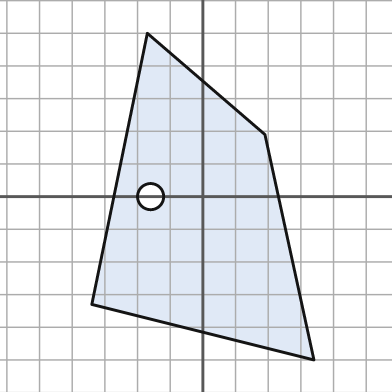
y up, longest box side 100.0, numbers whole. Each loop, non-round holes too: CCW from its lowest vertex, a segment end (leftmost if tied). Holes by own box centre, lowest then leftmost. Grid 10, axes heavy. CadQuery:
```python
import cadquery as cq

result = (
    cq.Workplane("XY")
    .moveTo(34.0, -50.0)
    .lineTo(19.0, 19.0)
    .lineTo(-17.0, 50.0)
    .lineTo(-34.0, -33.0)
    .close()
    .moveTo(-16.0, 0.0)
    .circle(4.0)
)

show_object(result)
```